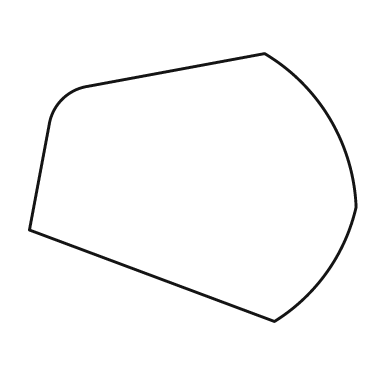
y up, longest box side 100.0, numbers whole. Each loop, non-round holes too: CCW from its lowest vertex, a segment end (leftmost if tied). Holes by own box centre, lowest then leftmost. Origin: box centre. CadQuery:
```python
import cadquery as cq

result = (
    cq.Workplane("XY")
    .moveTo(25.0, -41.0)
    .threePointArc((41.0, -26.0), (50.0, -6.0))
    .threePointArc((42.0, 21.0), (22.0, 41.0))
    .lineTo(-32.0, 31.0)
    .threePointArc((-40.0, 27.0), (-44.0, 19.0))
    .lineTo(-50.0, -13.0)
    .close()
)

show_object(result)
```